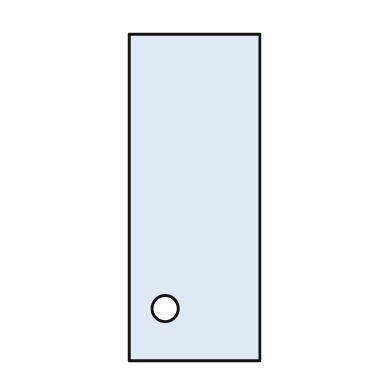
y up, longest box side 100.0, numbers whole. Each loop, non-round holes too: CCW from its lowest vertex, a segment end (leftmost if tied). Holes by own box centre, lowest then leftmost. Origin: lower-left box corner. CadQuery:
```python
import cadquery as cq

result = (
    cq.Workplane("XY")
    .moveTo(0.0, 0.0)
    .lineTo(40.0, 0.0)
    .lineTo(40.0, 100.0)
    .lineTo(0.0, 100.0)
    .close()
    .moveTo(11.0, 16.0)
    .circle(4.0)
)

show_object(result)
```